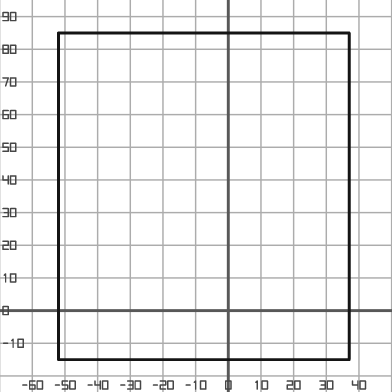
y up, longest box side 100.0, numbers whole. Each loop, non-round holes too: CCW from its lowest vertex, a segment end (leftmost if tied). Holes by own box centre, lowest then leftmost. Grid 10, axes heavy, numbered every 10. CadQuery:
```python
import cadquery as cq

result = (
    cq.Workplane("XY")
    .moveTo(-52.0, -15.0)
    .lineTo(37.0, -15.0)
    .lineTo(37.0, 85.0)
    .lineTo(-52.0, 85.0)
    .close()
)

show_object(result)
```